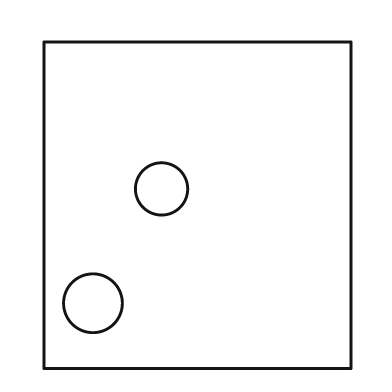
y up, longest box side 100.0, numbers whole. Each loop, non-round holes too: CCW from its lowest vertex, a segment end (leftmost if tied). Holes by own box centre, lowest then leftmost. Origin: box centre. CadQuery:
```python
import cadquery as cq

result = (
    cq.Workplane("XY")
    .moveTo(-47.0, -50.0)
    .lineTo(47.0, -50.0)
    .lineTo(47.0, 50.0)
    .lineTo(-47.0, 50.0)
    .close()
    .moveTo(-32.0, -30.0)
    .circle(9.0)
    .moveTo(-11.0, 5.0)
    .circle(8.0)
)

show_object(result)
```